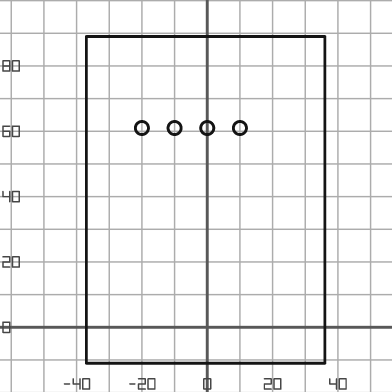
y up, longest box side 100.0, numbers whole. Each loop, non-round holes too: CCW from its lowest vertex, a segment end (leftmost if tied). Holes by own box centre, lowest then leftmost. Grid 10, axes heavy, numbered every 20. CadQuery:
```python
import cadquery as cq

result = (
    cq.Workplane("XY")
    .moveTo(-37.0, -11.0)
    .lineTo(36.0, -11.0)
    .lineTo(36.0, 89.0)
    .lineTo(-37.0, 89.0)
    .close()
    .moveTo(-20.0, 61.0)
    .circle(2.0)
    .moveTo(-10.0, 61.0)
    .circle(2.0)
    .moveTo(0.0, 61.0)
    .circle(2.0)
    .moveTo(10.0, 61.0)
    .circle(2.0)
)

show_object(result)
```